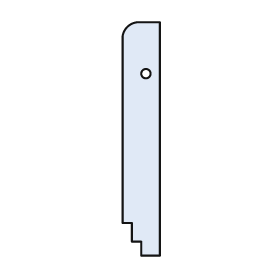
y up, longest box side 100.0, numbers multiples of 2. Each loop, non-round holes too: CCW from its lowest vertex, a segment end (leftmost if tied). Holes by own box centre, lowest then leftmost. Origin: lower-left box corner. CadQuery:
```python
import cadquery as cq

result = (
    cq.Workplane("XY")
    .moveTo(8.0, 0.0)
    .lineTo(16.0, 0.0)
    .lineTo(16.0, 100.0)
    .lineTo(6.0, 100.0)
    .threePointArc((2.0, 98.0), (0.0, 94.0))
    .lineTo(0.0, 14.0)
    .lineTo(4.0, 14.0)
    .lineTo(4.0, 6.0)
    .lineTo(8.0, 6.0)
    .close()
    .moveTo(10.0, 78.0)
    .circle(2.0)
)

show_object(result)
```